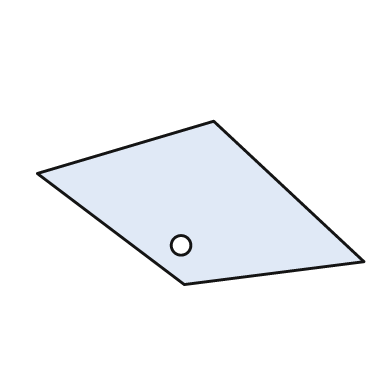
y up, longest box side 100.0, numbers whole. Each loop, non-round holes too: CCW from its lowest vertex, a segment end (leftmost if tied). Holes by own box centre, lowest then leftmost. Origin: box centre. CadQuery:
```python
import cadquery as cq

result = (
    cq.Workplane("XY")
    .moveTo(-5.0, -25.0)
    .lineTo(50.0, -18.0)
    .lineTo(4.0, 25.0)
    .lineTo(-50.0, 9.0)
    .close()
    .moveTo(-6.0, -13.0)
    .circle(3.0)
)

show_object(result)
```